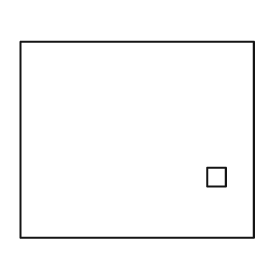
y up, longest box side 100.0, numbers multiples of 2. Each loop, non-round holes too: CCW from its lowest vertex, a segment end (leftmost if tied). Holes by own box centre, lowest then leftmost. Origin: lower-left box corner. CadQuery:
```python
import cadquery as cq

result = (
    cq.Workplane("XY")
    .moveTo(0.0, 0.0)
    .lineTo(100.0, 0.0)
    .lineTo(100.0, 84.0)
    .lineTo(0.0, 84.0)
    .close()
    .moveTo(80.0, 22.0)
    .lineTo(88.0, 22.0)
    .lineTo(88.0, 30.0)
    .lineTo(80.0, 30.0)
    .close()
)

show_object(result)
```